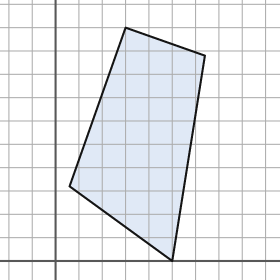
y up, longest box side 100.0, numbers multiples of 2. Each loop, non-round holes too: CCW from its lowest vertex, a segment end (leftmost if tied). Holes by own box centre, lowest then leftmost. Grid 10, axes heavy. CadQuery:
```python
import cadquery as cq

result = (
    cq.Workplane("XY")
    .moveTo(50.0, 0.0)
    .lineTo(64.0, 88.0)
    .lineTo(30.0, 100.0)
    .lineTo(6.0, 32.0)
    .close()
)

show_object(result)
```